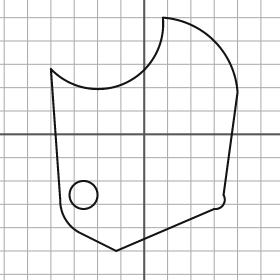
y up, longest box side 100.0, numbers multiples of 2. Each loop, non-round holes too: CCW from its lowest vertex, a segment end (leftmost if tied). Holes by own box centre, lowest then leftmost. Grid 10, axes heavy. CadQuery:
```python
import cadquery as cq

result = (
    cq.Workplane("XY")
    .moveTo(-12.0, -50.0)
    .lineTo(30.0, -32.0)
    .threePointArc((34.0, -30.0), (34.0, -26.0))
    .lineTo(40.0, 18.0)
    .threePointArc((30.0, 40.0), (8.0, 50.0))
    .threePointArc((-8.0, 22.0), (-40.0, 28.0))
    .lineTo(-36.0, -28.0)
    .threePointArc((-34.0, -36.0), (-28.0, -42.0))
    .close()
    .moveTo(-26.0, -26.0)
    .circle(6.0)
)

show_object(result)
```